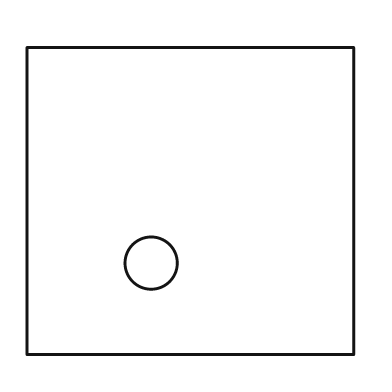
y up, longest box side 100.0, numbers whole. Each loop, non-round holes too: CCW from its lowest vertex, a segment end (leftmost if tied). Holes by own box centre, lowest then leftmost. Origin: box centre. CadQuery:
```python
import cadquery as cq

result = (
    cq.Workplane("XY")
    .moveTo(-50.0, -47.0)
    .lineTo(50.0, -47.0)
    .lineTo(50.0, 47.0)
    .lineTo(-50.0, 47.0)
    .close()
    .moveTo(-12.0, -19.0)
    .circle(8.0)
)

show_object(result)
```